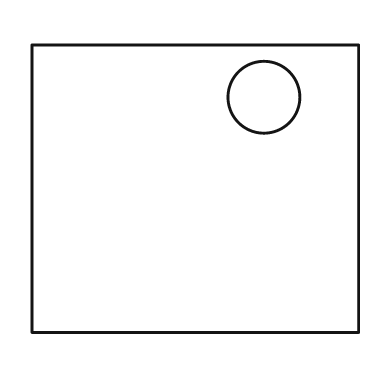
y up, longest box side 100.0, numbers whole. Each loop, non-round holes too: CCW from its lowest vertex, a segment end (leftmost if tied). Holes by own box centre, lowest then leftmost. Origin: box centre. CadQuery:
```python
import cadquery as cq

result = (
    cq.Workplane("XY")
    .moveTo(-50.0, -44.0)
    .lineTo(50.0, -44.0)
    .lineTo(50.0, 44.0)
    .lineTo(-50.0, 44.0)
    .close()
    .moveTo(21.0, 28.0)
    .circle(11.0)
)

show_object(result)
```